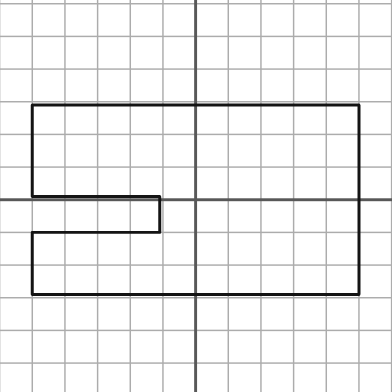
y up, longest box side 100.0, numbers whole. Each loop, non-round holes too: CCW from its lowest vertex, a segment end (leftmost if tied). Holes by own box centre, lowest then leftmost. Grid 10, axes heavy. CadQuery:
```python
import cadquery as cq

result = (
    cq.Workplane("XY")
    .moveTo(-50.0, -29.0)
    .lineTo(50.0, -29.0)
    .lineTo(50.0, 29.0)
    .lineTo(-50.0, 29.0)
    .lineTo(-50.0, 1.0)
    .lineTo(-11.0, 1.0)
    .lineTo(-11.0, -10.0)
    .lineTo(-50.0, -10.0)
    .close()
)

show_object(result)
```